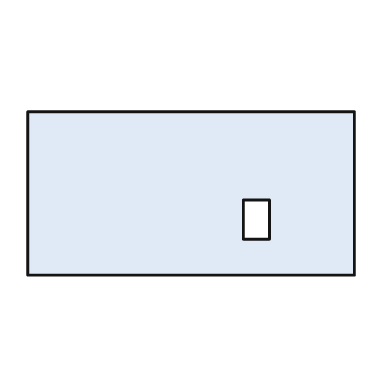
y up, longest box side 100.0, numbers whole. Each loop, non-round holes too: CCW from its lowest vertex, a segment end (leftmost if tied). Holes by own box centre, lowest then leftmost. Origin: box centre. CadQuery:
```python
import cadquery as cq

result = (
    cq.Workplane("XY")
    .moveTo(-50.0, -25.0)
    .lineTo(50.0, -25.0)
    .lineTo(50.0, 25.0)
    .lineTo(-50.0, 25.0)
    .close()
    .moveTo(16.0, -14.0)
    .lineTo(24.0, -14.0)
    .lineTo(24.0, -2.0)
    .lineTo(16.0, -2.0)
    .close()
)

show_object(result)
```